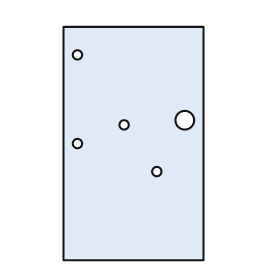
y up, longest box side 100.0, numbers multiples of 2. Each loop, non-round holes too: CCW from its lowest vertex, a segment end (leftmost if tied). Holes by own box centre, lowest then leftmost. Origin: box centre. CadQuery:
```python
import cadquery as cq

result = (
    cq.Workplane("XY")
    .moveTo(-30.0, -50.0)
    .lineTo(30.0, -50.0)
    .lineTo(30.0, 50.0)
    .lineTo(-30.0, 50.0)
    .close()
    .moveTo(10.0, -12.0)
    .circle(2.0)
    .moveTo(-24.0, 0.0)
    .circle(2.0)
    .moveTo(-4.0, 8.0)
    .circle(2.0)
    .moveTo(22.0, 10.0)
    .circle(4.0)
    .moveTo(-24.0, 38.0)
    .circle(2.0)
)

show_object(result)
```